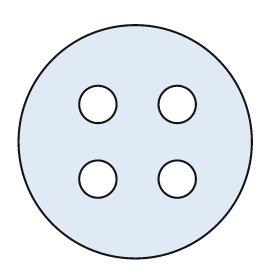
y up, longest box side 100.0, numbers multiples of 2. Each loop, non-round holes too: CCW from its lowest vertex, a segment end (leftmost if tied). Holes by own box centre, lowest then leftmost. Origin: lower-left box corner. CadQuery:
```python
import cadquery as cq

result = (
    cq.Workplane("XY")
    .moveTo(50.0, 50.0)
    .circle(50.0)
    .moveTo(34.0, 34.0)
    .circle(8.0)
    .moveTo(68.0, 34.0)
    .circle(8.0)
    .moveTo(34.0, 66.0)
    .circle(8.0)
    .moveTo(68.0, 66.0)
    .circle(8.0)
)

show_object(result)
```